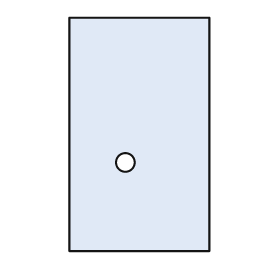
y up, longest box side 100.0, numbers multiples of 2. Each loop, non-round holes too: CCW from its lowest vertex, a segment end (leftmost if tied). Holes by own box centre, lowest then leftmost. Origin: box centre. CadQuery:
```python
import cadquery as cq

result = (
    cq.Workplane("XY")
    .moveTo(-30.0, -50.0)
    .lineTo(30.0, -50.0)
    .lineTo(30.0, 50.0)
    .lineTo(-30.0, 50.0)
    .close()
    .moveTo(-6.0, -12.0)
    .circle(4.0)
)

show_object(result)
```